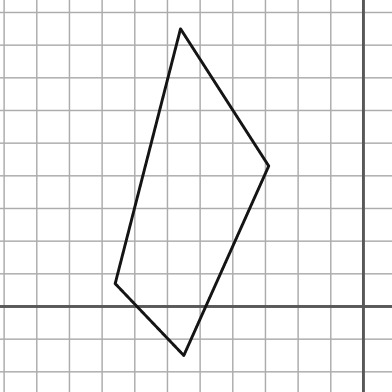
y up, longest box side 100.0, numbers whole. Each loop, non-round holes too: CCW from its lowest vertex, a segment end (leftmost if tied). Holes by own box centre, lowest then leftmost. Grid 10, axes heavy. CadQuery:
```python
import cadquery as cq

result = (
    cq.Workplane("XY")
    .moveTo(-55.0, -15.0)
    .lineTo(-29.0, 43.0)
    .lineTo(-56.0, 85.0)
    .lineTo(-76.0, 7.0)
    .close()
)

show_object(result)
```